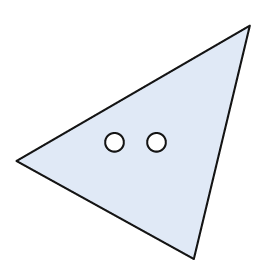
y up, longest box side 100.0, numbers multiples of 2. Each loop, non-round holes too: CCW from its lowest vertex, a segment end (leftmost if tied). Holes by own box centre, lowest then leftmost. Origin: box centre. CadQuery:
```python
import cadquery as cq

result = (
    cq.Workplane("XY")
    .moveTo(26.0, -50.0)
    .lineTo(50.0, 50.0)
    .lineTo(-50.0, -8.0)
    .close()
    .moveTo(-8.0, 0.0)
    .circle(4.0)
    .moveTo(10.0, 0.0)
    .circle(4.0)
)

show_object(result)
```